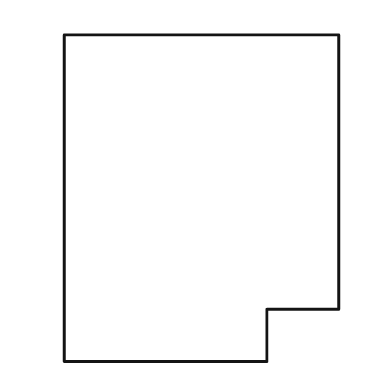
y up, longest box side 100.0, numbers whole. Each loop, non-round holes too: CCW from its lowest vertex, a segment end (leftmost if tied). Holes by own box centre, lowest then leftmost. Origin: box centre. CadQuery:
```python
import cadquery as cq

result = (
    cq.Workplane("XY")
    .moveTo(-42.0, -50.0)
    .lineTo(20.0, -50.0)
    .lineTo(20.0, -34.0)
    .lineTo(42.0, -34.0)
    .lineTo(42.0, 50.0)
    .lineTo(-42.0, 50.0)
    .close()
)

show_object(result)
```